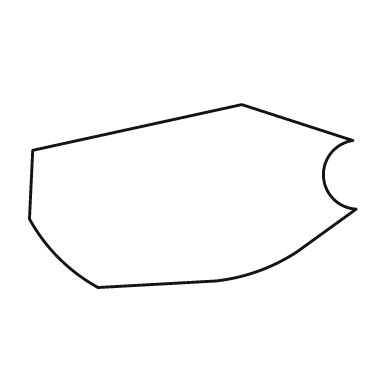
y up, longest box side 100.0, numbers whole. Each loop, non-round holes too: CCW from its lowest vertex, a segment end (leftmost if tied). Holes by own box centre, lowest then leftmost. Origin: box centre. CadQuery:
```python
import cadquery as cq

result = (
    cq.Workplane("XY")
    .moveTo(-29.0, -28.0)
    .lineTo(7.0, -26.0)
    .threePointArc((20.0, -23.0), (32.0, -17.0))
    .lineTo(50.0, -4.0)
    .threePointArc((40.0, 6.0), (49.0, 17.0))
    .lineTo(15.0, 28.0)
    .lineTo(-49.0, 14.0)
    .lineTo(-50.0, -7.0)
    .threePointArc((-41.0, -19.0), (-29.0, -28.0))
    .close()
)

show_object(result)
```